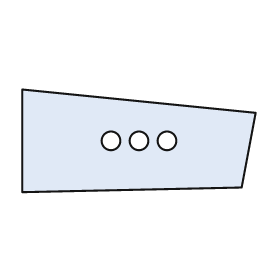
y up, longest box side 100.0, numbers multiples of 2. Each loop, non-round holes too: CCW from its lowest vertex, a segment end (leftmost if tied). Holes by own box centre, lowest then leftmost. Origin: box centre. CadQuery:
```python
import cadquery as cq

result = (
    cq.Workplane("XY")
    .moveTo(-50.0, -22.0)
    .lineTo(44.0, -20.0)
    .lineTo(50.0, 12.0)
    .lineTo(-50.0, 22.0)
    .close()
    .moveTo(-12.0, 0.0)
    .circle(4.0)
    .moveTo(0.0, 0.0)
    .circle(4.0)
    .moveTo(12.0, 0.0)
    .circle(4.0)
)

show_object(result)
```